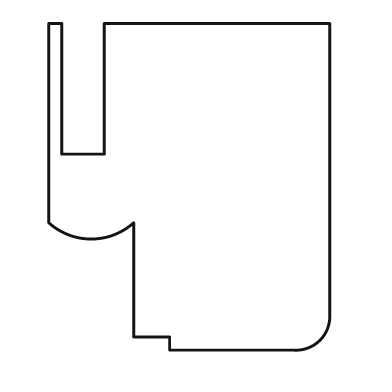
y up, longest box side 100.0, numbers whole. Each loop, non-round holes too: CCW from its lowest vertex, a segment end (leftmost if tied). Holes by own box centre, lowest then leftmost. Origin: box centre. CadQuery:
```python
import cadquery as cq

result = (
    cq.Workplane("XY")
    .moveTo(-6.0, -50.0)
    .lineTo(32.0, -50.0)
    .threePointArc((40.0, -47.0), (43.0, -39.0))
    .lineTo(43.0, 50.0)
    .lineTo(-26.0, 50.0)
    .lineTo(-26.0, 10.0)
    .lineTo(-39.0, 10.0)
    .lineTo(-39.0, 50.0)
    .lineTo(-43.0, 50.0)
    .lineTo(-43.0, -11.0)
    .threePointArc((-30.0, -16.0), (-17.0, -11.0))
    .lineTo(-17.0, -46.0)
    .lineTo(-6.0, -46.0)
    .close()
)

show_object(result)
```